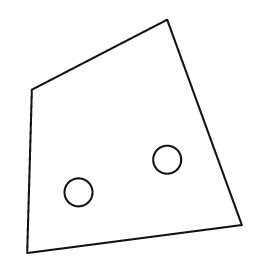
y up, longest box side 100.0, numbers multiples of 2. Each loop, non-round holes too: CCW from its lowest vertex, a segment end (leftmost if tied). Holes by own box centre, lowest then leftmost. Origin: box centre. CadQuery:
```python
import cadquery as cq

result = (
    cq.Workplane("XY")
    .moveTo(-46.0, -50.0)
    .lineTo(46.0, -38.0)
    .lineTo(14.0, 50.0)
    .lineTo(-44.0, 20.0)
    .close()
    .moveTo(-24.0, -24.0)
    .circle(6.0)
    .moveTo(14.0, -10.0)
    .circle(6.0)
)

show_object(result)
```